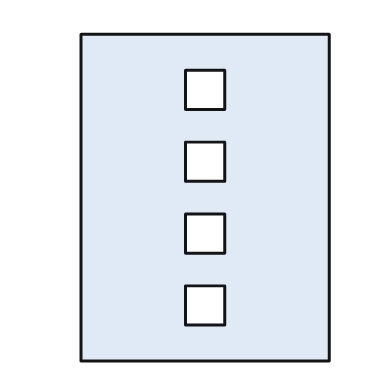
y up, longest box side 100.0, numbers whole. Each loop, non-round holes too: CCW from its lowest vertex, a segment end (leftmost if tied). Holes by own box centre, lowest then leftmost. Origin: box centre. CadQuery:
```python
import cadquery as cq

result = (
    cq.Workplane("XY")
    .moveTo(-38.0, -50.0)
    .lineTo(38.0, -50.0)
    .lineTo(38.0, 50.0)
    .lineTo(-38.0, 50.0)
    .close()
    .moveTo(-6.0, -39.0)
    .lineTo(6.0, -39.0)
    .lineTo(6.0, -27.0)
    .lineTo(-6.0, -27.0)
    .close()
    .moveTo(-6.0, -17.0)
    .lineTo(6.0, -17.0)
    .lineTo(6.0, -5.0)
    .lineTo(-6.0, -5.0)
    .close()
    .moveTo(-6.0, 5.0)
    .lineTo(6.0, 5.0)
    .lineTo(6.0, 17.0)
    .lineTo(-6.0, 17.0)
    .close()
    .moveTo(-6.0, 27.0)
    .lineTo(6.0, 27.0)
    .lineTo(6.0, 39.0)
    .lineTo(-6.0, 39.0)
    .close()
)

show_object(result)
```